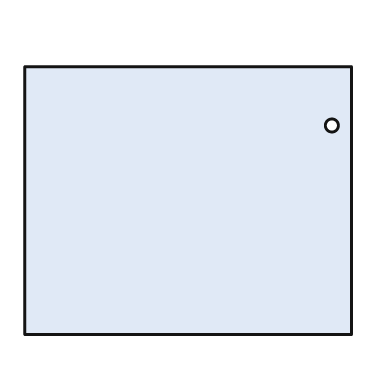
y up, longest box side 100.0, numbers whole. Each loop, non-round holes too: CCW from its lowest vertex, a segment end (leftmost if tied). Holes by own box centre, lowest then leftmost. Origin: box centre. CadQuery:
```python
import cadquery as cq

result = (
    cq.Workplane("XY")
    .moveTo(-50.0, -41.0)
    .lineTo(50.0, -41.0)
    .lineTo(50.0, 41.0)
    .lineTo(-50.0, 41.0)
    .close()
    .moveTo(44.0, 23.0)
    .circle(2.0)
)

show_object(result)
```